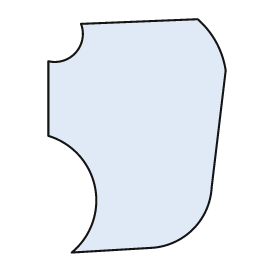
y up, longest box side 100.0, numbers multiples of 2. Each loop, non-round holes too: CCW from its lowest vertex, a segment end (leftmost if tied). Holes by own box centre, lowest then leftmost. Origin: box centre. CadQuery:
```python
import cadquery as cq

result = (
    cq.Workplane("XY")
    .moveTo(-28.0, -50.0)
    .lineTo(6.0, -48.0)
    .threePointArc((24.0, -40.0), (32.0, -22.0))
    .lineTo(38.0, 28.0)
    .threePointArc((34.0, 40.0), (26.0, 50.0))
    .lineTo(-24.0, 48.0)
    .threePointArc((-26.0, 36.0), (-38.0, 32.0))
    .lineTo(-38.0, 0.0)
    .threePointArc((-18.0, -22.0), (-28.0, -50.0))
    .close()
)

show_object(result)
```